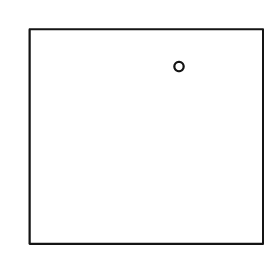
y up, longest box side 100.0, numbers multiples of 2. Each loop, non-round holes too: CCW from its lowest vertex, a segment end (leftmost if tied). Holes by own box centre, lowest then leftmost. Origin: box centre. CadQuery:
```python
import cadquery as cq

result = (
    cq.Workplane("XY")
    .moveTo(-50.0, -46.0)
    .lineTo(50.0, -46.0)
    .lineTo(50.0, 46.0)
    .lineTo(-50.0, 46.0)
    .close()
    .moveTo(14.0, 30.0)
    .circle(2.0)
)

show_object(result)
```